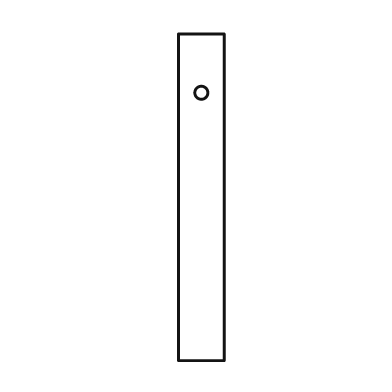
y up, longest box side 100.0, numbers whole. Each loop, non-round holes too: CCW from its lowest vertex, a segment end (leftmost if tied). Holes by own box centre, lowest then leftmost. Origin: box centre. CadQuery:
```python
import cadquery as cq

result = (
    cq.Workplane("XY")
    .moveTo(-7.0, -50.0)
    .lineTo(7.0, -50.0)
    .lineTo(7.0, 50.0)
    .lineTo(-7.0, 50.0)
    .close()
    .moveTo(0.0, 32.0)
    .circle(2.0)
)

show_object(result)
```